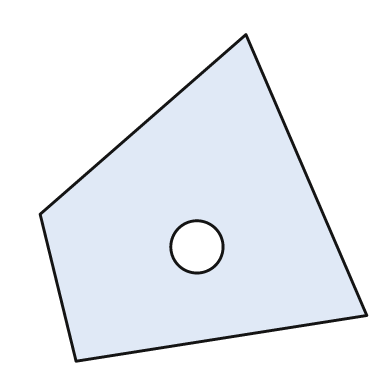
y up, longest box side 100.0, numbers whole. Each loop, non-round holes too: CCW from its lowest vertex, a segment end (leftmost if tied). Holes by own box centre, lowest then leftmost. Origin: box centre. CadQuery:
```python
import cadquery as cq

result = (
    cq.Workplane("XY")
    .moveTo(-39.0, -50.0)
    .lineTo(50.0, -36.0)
    .lineTo(13.0, 50.0)
    .lineTo(-50.0, -5.0)
    .close()
    .moveTo(-2.0, -15.0)
    .circle(8.0)
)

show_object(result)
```